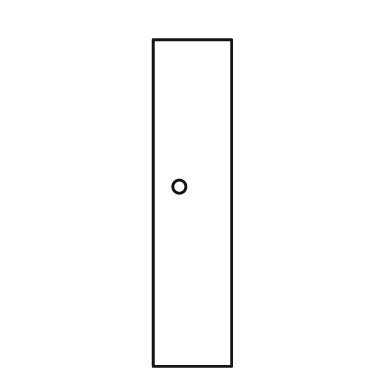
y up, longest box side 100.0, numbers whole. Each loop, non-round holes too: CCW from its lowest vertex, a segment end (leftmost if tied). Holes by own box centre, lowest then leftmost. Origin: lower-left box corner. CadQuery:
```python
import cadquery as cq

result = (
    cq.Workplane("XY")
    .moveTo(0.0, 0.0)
    .lineTo(24.0, 0.0)
    .lineTo(24.0, 100.0)
    .lineTo(0.0, 100.0)
    .close()
    .moveTo(8.0, 55.0)
    .circle(2.0)
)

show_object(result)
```